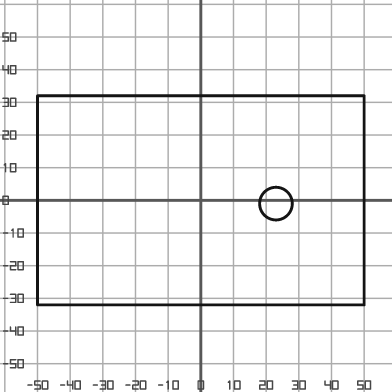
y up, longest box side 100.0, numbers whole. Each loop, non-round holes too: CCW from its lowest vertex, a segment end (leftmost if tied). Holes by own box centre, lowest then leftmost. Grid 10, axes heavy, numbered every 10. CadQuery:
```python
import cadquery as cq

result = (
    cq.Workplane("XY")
    .moveTo(-50.0, -32.0)
    .lineTo(50.0, -32.0)
    .lineTo(50.0, 32.0)
    .lineTo(-50.0, 32.0)
    .close()
    .moveTo(23.0, -1.0)
    .circle(5.0)
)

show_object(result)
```